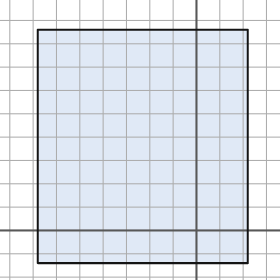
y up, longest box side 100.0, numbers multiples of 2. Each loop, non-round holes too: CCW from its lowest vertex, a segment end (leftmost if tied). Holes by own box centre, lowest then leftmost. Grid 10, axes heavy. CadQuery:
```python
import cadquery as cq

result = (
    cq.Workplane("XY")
    .moveTo(-68.0, -14.0)
    .lineTo(22.0, -14.0)
    .lineTo(22.0, 86.0)
    .lineTo(-68.0, 86.0)
    .close()
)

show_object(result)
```